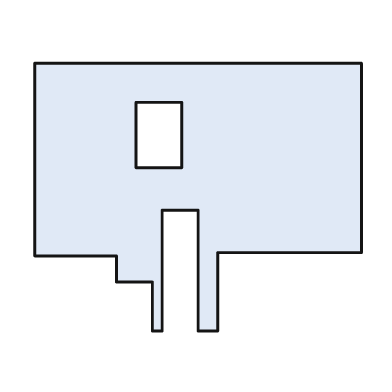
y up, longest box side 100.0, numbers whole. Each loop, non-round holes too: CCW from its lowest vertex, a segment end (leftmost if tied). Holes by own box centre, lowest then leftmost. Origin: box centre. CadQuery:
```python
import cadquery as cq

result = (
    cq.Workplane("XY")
    .moveTo(-14.0, -41.0)
    .lineTo(-11.0, -41.0)
    .lineTo(-11.0, -4.0)
    .lineTo(0.0, -4.0)
    .lineTo(0.0, -41.0)
    .lineTo(6.0, -41.0)
    .lineTo(6.0, -17.0)
    .lineTo(50.0, -17.0)
    .lineTo(50.0, 41.0)
    .lineTo(-50.0, 41.0)
    .lineTo(-50.0, -18.0)
    .lineTo(-25.0, -18.0)
    .lineTo(-25.0, -26.0)
    .lineTo(-14.0, -26.0)
    .close()
    .moveTo(-19.0, 9.0)
    .lineTo(-5.0, 9.0)
    .lineTo(-5.0, 29.0)
    .lineTo(-19.0, 29.0)
    .close()
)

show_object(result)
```